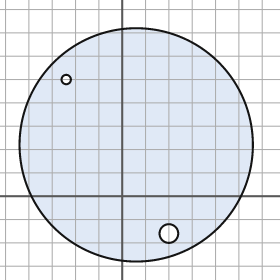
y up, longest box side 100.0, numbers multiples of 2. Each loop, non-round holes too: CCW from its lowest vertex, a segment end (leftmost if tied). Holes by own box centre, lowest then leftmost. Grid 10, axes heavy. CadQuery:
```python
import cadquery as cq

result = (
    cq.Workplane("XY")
    .moveTo(6.0, 22.0)
    .circle(50.0)
    .moveTo(20.0, -16.0)
    .circle(4.0)
    .moveTo(-24.0, 50.0)
    .circle(2.0)
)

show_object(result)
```